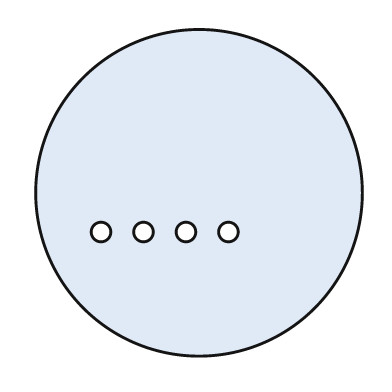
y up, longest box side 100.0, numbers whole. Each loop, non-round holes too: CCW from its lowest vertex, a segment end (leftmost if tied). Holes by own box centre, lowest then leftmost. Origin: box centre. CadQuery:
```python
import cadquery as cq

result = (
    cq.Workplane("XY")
    .moveTo(0.0, 0.0)
    .circle(50.0)
    .moveTo(-30.0, -12.0)
    .circle(3.0)
    .moveTo(-17.0, -12.0)
    .circle(3.0)
    .moveTo(-4.0, -12.0)
    .circle(3.0)
    .moveTo(9.0, -12.0)
    .circle(3.0)
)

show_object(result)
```